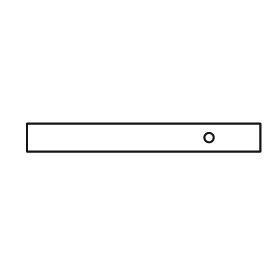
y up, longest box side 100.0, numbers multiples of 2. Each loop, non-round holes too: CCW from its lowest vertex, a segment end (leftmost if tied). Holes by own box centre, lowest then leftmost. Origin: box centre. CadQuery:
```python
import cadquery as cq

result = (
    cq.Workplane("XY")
    .moveTo(-50.0, -6.0)
    .lineTo(50.0, -6.0)
    .lineTo(50.0, 6.0)
    .lineTo(-50.0, 6.0)
    .close()
    .moveTo(28.0, 0.0)
    .circle(2.0)
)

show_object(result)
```